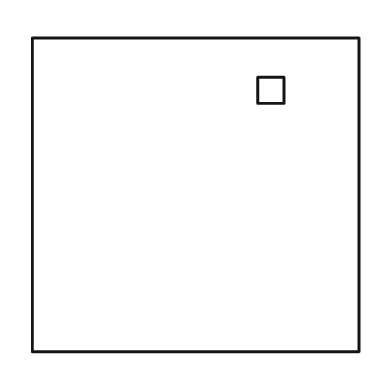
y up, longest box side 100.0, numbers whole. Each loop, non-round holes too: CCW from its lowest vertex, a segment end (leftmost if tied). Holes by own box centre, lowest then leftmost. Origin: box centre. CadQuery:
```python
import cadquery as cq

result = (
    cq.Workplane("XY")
    .moveTo(-50.0, -48.0)
    .lineTo(50.0, -48.0)
    .lineTo(50.0, 48.0)
    .lineTo(-50.0, 48.0)
    .close()
    .moveTo(19.0, 28.0)
    .lineTo(27.0, 28.0)
    .lineTo(27.0, 36.0)
    .lineTo(19.0, 36.0)
    .close()
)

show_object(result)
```